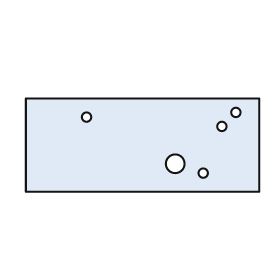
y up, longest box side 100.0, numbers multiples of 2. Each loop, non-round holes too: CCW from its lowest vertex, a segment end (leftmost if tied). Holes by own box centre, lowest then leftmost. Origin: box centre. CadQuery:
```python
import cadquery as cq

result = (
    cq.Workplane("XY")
    .moveTo(-50.0, -20.0)
    .lineTo(50.0, -20.0)
    .lineTo(50.0, 20.0)
    .lineTo(-50.0, 20.0)
    .close()
    .moveTo(26.0, -12.0)
    .circle(2.0)
    .moveTo(14.0, -8.0)
    .circle(4.0)
    .moveTo(34.0, 8.0)
    .circle(2.0)
    .moveTo(-24.0, 12.0)
    .circle(2.0)
    .moveTo(40.0, 14.0)
    .circle(2.0)
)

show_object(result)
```